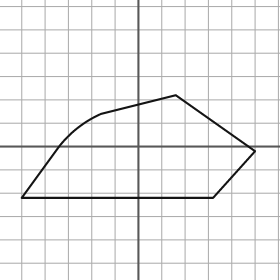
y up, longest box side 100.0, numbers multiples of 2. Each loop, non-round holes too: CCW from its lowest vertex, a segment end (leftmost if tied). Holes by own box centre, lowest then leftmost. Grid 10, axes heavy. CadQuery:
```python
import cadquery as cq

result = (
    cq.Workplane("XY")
    .moveTo(-50.0, -22.0)
    .lineTo(32.0, -22.0)
    .lineTo(50.0, -2.0)
    .lineTo(16.0, 22.0)
    .lineTo(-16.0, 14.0)
    .threePointArc((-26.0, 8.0), (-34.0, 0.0))
    .close()
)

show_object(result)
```